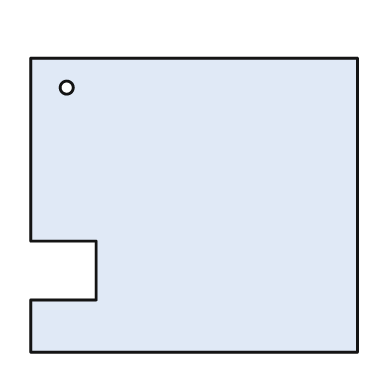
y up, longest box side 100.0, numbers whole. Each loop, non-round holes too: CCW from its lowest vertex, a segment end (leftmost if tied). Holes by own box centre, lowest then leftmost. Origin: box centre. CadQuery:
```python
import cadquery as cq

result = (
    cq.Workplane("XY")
    .moveTo(-50.0, -45.0)
    .lineTo(50.0, -45.0)
    .lineTo(50.0, 45.0)
    .lineTo(-50.0, 45.0)
    .lineTo(-50.0, -11.0)
    .lineTo(-30.0, -11.0)
    .lineTo(-30.0, -29.0)
    .lineTo(-50.0, -29.0)
    .close()
    .moveTo(-39.0, 36.0)
    .circle(2.0)
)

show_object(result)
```